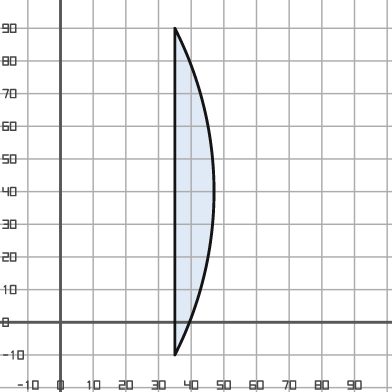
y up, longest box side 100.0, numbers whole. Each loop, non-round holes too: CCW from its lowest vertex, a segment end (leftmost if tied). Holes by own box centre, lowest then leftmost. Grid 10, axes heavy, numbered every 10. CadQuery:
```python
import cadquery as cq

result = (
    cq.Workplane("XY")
    .moveTo(35.0, -10.0)
    .threePointArc((47.0, 40.0), (35.0, 90.0))
    .close()
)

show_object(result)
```